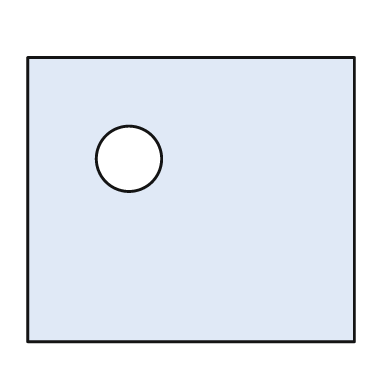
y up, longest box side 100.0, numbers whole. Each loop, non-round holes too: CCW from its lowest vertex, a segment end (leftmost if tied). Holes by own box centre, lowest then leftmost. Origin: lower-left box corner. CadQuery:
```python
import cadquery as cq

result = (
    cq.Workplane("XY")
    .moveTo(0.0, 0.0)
    .lineTo(100.0, 0.0)
    .lineTo(100.0, 87.0)
    .lineTo(0.0, 87.0)
    .close()
    .moveTo(31.0, 56.0)
    .circle(10.0)
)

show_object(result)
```